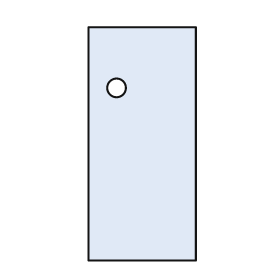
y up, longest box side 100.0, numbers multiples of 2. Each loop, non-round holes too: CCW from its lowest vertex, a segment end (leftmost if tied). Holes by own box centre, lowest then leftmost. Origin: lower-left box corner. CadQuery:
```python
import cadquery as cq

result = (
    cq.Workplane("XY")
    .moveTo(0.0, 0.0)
    .lineTo(46.0, 0.0)
    .lineTo(46.0, 100.0)
    .lineTo(0.0, 100.0)
    .close()
    .moveTo(12.0, 74.0)
    .circle(4.0)
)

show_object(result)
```